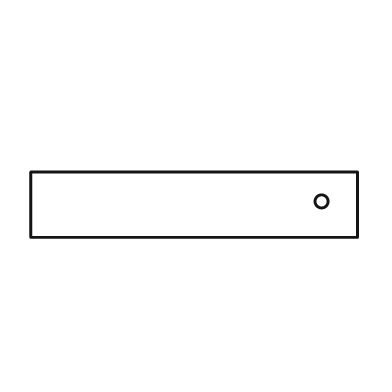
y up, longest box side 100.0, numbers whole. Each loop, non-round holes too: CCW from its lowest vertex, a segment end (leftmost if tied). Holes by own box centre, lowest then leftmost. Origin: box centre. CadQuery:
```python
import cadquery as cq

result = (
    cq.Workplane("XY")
    .moveTo(-50.0, -10.0)
    .lineTo(50.0, -10.0)
    .lineTo(50.0, 10.0)
    .lineTo(-50.0, 10.0)
    .close()
    .moveTo(39.0, 1.0)
    .circle(2.0)
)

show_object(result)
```